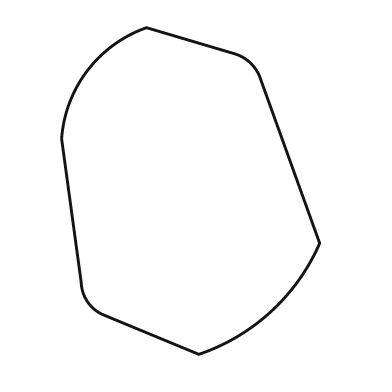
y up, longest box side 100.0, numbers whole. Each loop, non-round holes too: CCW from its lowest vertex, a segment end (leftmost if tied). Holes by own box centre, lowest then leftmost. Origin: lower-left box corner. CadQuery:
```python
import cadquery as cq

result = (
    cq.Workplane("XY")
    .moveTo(42.0, 0.0)
    .threePointArc((64.0, 13.0), (79.0, 34.0))
    .lineTo(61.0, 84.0)
    .threePointArc((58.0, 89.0), (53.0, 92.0))
    .lineTo(26.0, 100.0)
    .threePointArc((8.0, 87.0), (0.0, 66.0))
    .lineTo(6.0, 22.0)
    .threePointArc((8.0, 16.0), (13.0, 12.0))
    .close()
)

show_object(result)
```